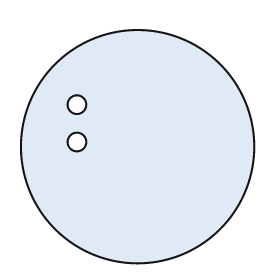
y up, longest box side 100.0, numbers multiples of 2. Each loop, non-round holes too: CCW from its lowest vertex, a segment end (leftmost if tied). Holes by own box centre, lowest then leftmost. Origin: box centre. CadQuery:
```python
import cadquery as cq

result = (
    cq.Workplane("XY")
    .moveTo(0.0, 0.0)
    .circle(50.0)
    .moveTo(-26.0, 2.0)
    .circle(4.0)
    .moveTo(-26.0, 18.0)
    .circle(4.0)
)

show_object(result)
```